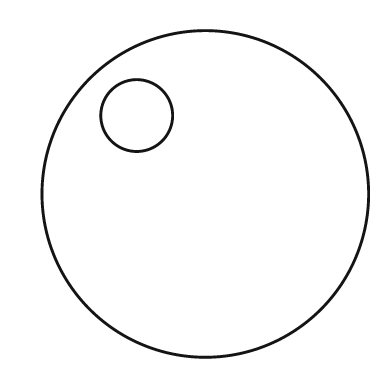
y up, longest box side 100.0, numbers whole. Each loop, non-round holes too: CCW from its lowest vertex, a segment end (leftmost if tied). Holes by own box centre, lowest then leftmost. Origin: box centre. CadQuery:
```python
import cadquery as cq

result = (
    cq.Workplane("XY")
    .moveTo(0.0, 0.0)
    .circle(50.0)
    .moveTo(-21.0, 24.0)
    .circle(11.0)
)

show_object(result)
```